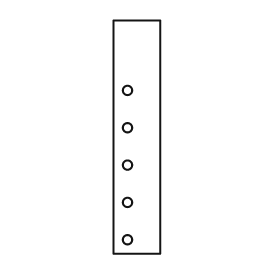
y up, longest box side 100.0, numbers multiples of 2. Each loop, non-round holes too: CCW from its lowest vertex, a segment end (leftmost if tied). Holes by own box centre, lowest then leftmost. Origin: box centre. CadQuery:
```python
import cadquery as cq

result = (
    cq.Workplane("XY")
    .moveTo(-10.0, -50.0)
    .lineTo(10.0, -50.0)
    .lineTo(10.0, 50.0)
    .lineTo(-10.0, 50.0)
    .close()
    .moveTo(-4.0, -44.0)
    .circle(2.0)
    .moveTo(-4.0, -28.0)
    .circle(2.0)
    .moveTo(-4.0, -12.0)
    .circle(2.0)
    .moveTo(-4.0, 4.0)
    .circle(2.0)
    .moveTo(-4.0, 20.0)
    .circle(2.0)
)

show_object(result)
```